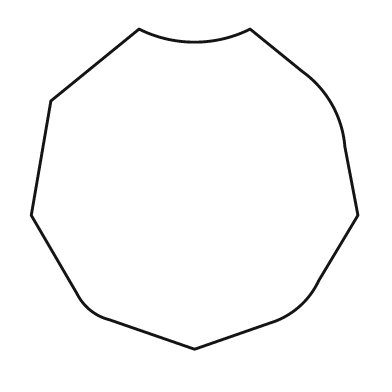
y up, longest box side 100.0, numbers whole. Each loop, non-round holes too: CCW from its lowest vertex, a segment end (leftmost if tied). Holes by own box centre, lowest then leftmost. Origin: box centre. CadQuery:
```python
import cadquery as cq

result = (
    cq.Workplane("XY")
    .moveTo(0.0, -49.0)
    .lineTo(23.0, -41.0)
    .threePointArc((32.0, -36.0), (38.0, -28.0))
    .lineTo(50.0, -8.0)
    .lineTo(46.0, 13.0)
    .threePointArc((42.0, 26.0), (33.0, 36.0))
    .lineTo(17.0, 49.0)
    .threePointArc((0.0, 45.0), (-17.0, 49.0))
    .lineTo(-44.0, 27.0)
    .lineTo(-50.0, -8.0)
    .lineTo(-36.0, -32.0)
    .threePointArc((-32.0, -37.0), (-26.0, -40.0))
    .close()
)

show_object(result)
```